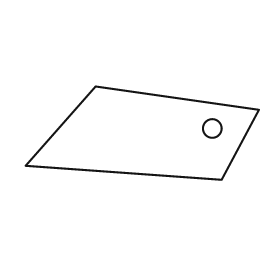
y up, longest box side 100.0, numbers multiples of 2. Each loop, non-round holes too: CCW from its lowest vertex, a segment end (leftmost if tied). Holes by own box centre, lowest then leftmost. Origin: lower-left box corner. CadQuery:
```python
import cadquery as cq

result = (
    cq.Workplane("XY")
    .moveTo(84.0, 0.0)
    .lineTo(100.0, 30.0)
    .lineTo(30.0, 40.0)
    .lineTo(0.0, 6.0)
    .close()
    .moveTo(80.0, 22.0)
    .circle(4.0)
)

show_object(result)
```